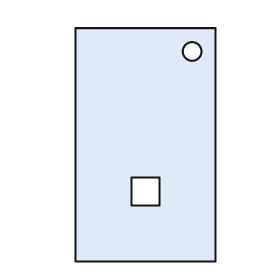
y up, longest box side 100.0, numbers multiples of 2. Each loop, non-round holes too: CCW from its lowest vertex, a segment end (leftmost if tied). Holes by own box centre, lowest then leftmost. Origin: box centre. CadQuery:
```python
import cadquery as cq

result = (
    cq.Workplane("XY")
    .moveTo(-30.0, -50.0)
    .lineTo(30.0, -50.0)
    .lineTo(30.0, 50.0)
    .lineTo(-30.0, 50.0)
    .close()
    .moveTo(-6.0, -26.0)
    .lineTo(6.0, -26.0)
    .lineTo(6.0, -14.0)
    .lineTo(-6.0, -14.0)
    .close()
    .moveTo(20.0, 40.0)
    .circle(4.0)
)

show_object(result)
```